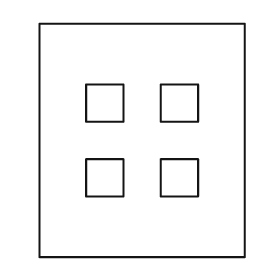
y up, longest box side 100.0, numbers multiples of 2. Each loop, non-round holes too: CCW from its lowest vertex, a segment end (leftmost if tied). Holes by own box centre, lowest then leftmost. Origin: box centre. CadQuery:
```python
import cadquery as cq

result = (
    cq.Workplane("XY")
    .moveTo(-44.0, -50.0)
    .lineTo(44.0, -50.0)
    .lineTo(44.0, 50.0)
    .lineTo(-44.0, 50.0)
    .close()
    .moveTo(-24.0, -24.0)
    .lineTo(-8.0, -24.0)
    .lineTo(-8.0, -8.0)
    .lineTo(-24.0, -8.0)
    .close()
    .moveTo(8.0, -24.0)
    .lineTo(24.0, -24.0)
    .lineTo(24.0, -8.0)
    .lineTo(8.0, -8.0)
    .close()
    .moveTo(-24.0, 8.0)
    .lineTo(-8.0, 8.0)
    .lineTo(-8.0, 24.0)
    .lineTo(-24.0, 24.0)
    .close()
    .moveTo(8.0, 8.0)
    .lineTo(24.0, 8.0)
    .lineTo(24.0, 24.0)
    .lineTo(8.0, 24.0)
    .close()
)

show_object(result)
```